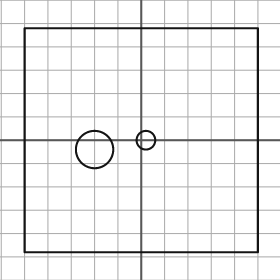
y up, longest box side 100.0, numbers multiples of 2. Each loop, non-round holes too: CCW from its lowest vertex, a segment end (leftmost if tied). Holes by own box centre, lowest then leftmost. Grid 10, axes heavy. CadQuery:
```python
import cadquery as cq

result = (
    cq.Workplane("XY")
    .moveTo(-50.0, -48.0)
    .lineTo(50.0, -48.0)
    .lineTo(50.0, 48.0)
    .lineTo(-50.0, 48.0)
    .close()
    .moveTo(-20.0, -4.0)
    .circle(8.0)
    .moveTo(2.0, 0.0)
    .circle(4.0)
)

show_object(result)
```